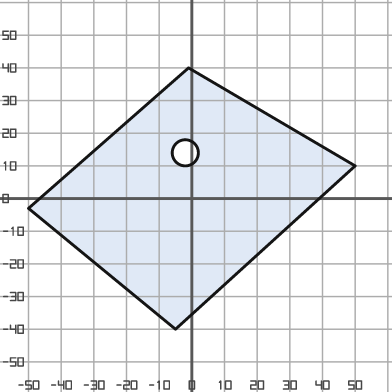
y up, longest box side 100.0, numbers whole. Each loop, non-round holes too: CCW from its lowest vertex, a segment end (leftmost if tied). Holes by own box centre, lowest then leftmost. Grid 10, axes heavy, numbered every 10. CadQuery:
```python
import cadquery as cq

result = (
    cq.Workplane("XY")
    .moveTo(-5.0, -40.0)
    .lineTo(50.0, 10.0)
    .lineTo(-1.0, 40.0)
    .lineTo(-50.0, -3.0)
    .close()
    .moveTo(-2.0, 14.0)
    .circle(4.0)
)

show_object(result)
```